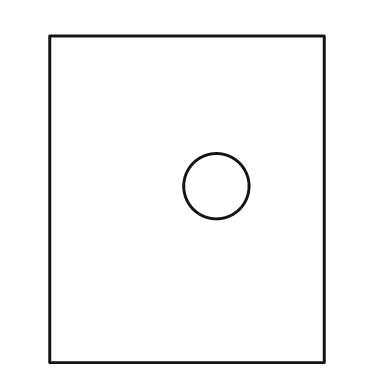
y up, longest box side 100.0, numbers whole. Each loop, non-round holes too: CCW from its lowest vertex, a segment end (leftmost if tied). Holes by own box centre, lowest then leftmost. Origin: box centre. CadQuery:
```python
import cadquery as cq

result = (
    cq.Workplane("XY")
    .moveTo(-42.0, -50.0)
    .lineTo(42.0, -50.0)
    .lineTo(42.0, 50.0)
    .lineTo(-42.0, 50.0)
    .close()
    .moveTo(9.0, 4.0)
    .circle(10.0)
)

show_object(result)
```